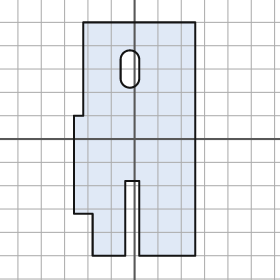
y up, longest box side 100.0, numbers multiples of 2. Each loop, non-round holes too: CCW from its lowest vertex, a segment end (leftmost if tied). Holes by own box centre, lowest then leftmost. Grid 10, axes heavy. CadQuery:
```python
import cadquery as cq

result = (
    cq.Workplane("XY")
    .moveTo(-18.0, -50.0)
    .lineTo(-4.0, -50.0)
    .lineTo(-4.0, -18.0)
    .lineTo(2.0, -18.0)
    .lineTo(2.0, -50.0)
    .lineTo(26.0, -50.0)
    .lineTo(26.0, 50.0)
    .lineTo(-22.0, 50.0)
    .lineTo(-22.0, 10.0)
    .lineTo(-26.0, 10.0)
    .lineTo(-26.0, -32.0)
    .lineTo(-18.0, -32.0)
    .close()
    .moveTo(-6.0, 26.0)
    .threePointArc((-2.0, 22.0), (2.0, 26.0))
    .lineTo(2.0, 34.0)
    .threePointArc((-2.0, 38.0), (-6.0, 34.0))
    .close()
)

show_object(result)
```